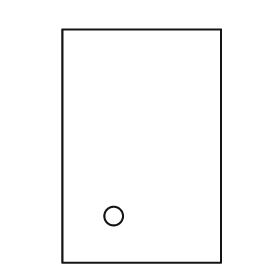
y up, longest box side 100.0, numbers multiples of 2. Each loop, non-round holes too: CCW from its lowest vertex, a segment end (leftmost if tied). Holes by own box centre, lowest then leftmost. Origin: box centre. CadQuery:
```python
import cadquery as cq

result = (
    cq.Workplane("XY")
    .moveTo(-34.0, -50.0)
    .lineTo(34.0, -50.0)
    .lineTo(34.0, 50.0)
    .lineTo(-34.0, 50.0)
    .close()
    .moveTo(-12.0, -30.0)
    .circle(4.0)
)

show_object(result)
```